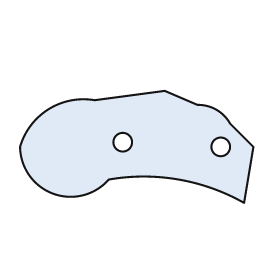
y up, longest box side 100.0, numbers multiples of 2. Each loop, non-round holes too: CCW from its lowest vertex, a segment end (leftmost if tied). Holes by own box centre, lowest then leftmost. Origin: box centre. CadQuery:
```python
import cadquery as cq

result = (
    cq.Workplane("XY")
    .moveTo(46.0, -24.0)
    .lineTo(50.0, 0.0)
    .lineTo(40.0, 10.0)
    .threePointArc((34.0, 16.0), (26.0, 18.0))
    .lineTo(12.0, 24.0)
    .lineTo(-18.0, 20.0)
    .threePointArc((-38.0, 16.0), (-50.0, 0.0))
    .threePointArc((-36.0, -20.0), (-12.0, -14.0))
    .threePointArc((18.0, -14.0), (46.0, -24.0))
    .close()
    .moveTo(36.0, 0.0)
    .circle(4.0)
    .moveTo(-6.0, 2.0)
    .circle(4.0)
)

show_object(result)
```